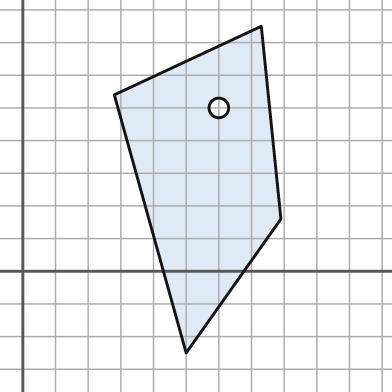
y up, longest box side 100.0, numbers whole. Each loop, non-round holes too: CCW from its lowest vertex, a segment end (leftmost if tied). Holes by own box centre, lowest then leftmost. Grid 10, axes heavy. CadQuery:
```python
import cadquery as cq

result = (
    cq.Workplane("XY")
    .moveTo(50.0, -25.0)
    .lineTo(79.0, 16.0)
    .lineTo(73.0, 75.0)
    .lineTo(28.0, 54.0)
    .close()
    .moveTo(60.0, 50.0)
    .circle(3.0)
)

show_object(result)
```